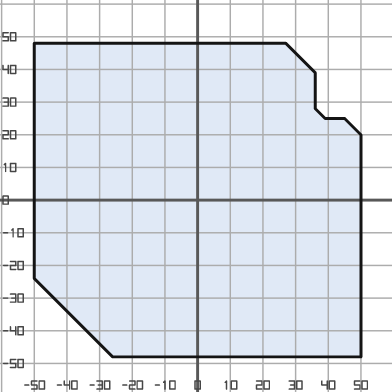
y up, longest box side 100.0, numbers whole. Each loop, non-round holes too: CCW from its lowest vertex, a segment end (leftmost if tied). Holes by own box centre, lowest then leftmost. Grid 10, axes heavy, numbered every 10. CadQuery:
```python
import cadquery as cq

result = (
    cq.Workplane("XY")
    .moveTo(-26.0, -48.0)
    .lineTo(50.0, -48.0)
    .lineTo(50.0, 20.0)
    .lineTo(45.0, 25.0)
    .lineTo(39.0, 25.0)
    .lineTo(36.0, 28.0)
    .lineTo(36.0, 39.0)
    .lineTo(27.0, 48.0)
    .lineTo(-50.0, 48.0)
    .lineTo(-50.0, -24.0)
    .close()
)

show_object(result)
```